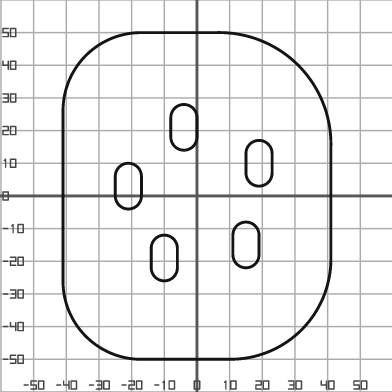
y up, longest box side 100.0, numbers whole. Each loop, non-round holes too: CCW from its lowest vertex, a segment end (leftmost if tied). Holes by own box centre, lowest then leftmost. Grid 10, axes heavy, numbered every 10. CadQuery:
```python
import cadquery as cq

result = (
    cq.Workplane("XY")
    .moveTo(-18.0, -50.0)
    .lineTo(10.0, -50.0)
    .threePointArc((32.0, -41.0), (41.0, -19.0))
    .lineTo(41.0, 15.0)
    .threePointArc((31.0, 40.0), (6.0, 50.0))
    .lineTo(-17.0, 50.0)
    .threePointArc((-34.0, 43.0), (-41.0, 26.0))
    .lineTo(-41.0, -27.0)
    .threePointArc((-34.0, -43.0), (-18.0, -50.0))
    .close()
    .moveTo(-14.0, -22.0)
    .threePointArc((-10.0, -26.0), (-6.0, -22.0))
    .lineTo(-6.0, -16.0)
    .threePointArc((-10.0, -12.0), (-14.0, -16.0))
    .close()
    .moveTo(11.0, -18.0)
    .threePointArc((15.0, -22.0), (19.0, -18.0))
    .lineTo(19.0, -12.0)
    .threePointArc((15.0, -8.0), (11.0, -12.0))
    .close()
    .moveTo(-25.0, 0.0)
    .threePointArc((-21.0, -4.0), (-17.0, 0.0))
    .lineTo(-17.0, 6.0)
    .threePointArc((-21.0, 10.0), (-25.0, 6.0))
    .close()
    .moveTo(15.0, 7.0)
    .threePointArc((19.0, 3.0), (23.0, 7.0))
    .lineTo(23.0, 13.0)
    .threePointArc((19.0, 17.0), (15.0, 13.0))
    .close()
    .moveTo(-8.0, 18.0)
    .threePointArc((-4.0, 14.0), (0.0, 18.0))
    .lineTo(0.0, 24.0)
    .threePointArc((-4.0, 28.0), (-8.0, 24.0))
    .close()
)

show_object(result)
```